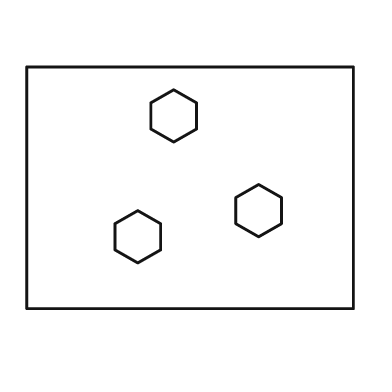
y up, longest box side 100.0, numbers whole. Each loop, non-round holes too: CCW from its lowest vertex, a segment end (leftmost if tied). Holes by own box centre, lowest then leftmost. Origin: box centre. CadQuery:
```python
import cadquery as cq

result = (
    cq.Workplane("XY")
    .moveTo(-50.0, -37.0)
    .lineTo(50.0, -37.0)
    .lineTo(50.0, 37.0)
    .lineTo(-50.0, 37.0)
    .close()
    .moveTo(-16.0, -23.0)
    .lineTo(-9.0, -19.0)
    .lineTo(-9.0, -11.0)
    .lineTo(-16.0, -7.0)
    .lineTo(-23.0, -11.0)
    .lineTo(-23.0, -19.0)
    .close()
    .moveTo(21.0, -15.0)
    .lineTo(28.0, -11.0)
    .lineTo(28.0, -3.0)
    .lineTo(21.0, 1.0)
    .lineTo(14.0, -3.0)
    .lineTo(14.0, -11.0)
    .close()
    .moveTo(-5.0, 14.0)
    .lineTo(2.0, 18.0)
    .lineTo(2.0, 26.0)
    .lineTo(-5.0, 30.0)
    .lineTo(-12.0, 26.0)
    .lineTo(-12.0, 18.0)
    .close()
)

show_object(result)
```